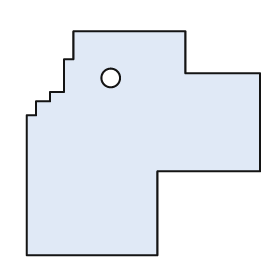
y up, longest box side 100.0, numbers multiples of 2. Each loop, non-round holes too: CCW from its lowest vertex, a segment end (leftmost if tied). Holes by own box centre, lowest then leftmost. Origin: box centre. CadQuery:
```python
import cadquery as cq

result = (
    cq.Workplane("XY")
    .moveTo(-50.0, -48.0)
    .lineTo(6.0, -48.0)
    .lineTo(6.0, -12.0)
    .lineTo(50.0, -12.0)
    .lineTo(50.0, 30.0)
    .lineTo(18.0, 30.0)
    .lineTo(18.0, 48.0)
    .lineTo(-30.0, 48.0)
    .lineTo(-30.0, 36.0)
    .lineTo(-34.0, 36.0)
    .lineTo(-34.0, 22.0)
    .lineTo(-40.0, 22.0)
    .lineTo(-40.0, 18.0)
    .lineTo(-46.0, 18.0)
    .lineTo(-46.0, 12.0)
    .lineTo(-50.0, 12.0)
    .close()
    .moveTo(-14.0, 28.0)
    .circle(4.0)
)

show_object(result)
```